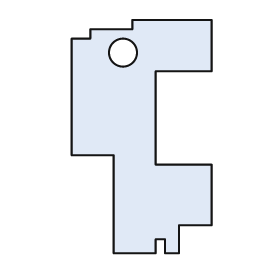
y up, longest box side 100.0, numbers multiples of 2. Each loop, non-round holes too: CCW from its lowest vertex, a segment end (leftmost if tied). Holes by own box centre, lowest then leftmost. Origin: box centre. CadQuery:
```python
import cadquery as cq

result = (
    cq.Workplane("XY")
    .moveTo(-12.0, -50.0)
    .lineTo(6.0, -50.0)
    .lineTo(6.0, -44.0)
    .lineTo(10.0, -44.0)
    .lineTo(10.0, -50.0)
    .lineTo(16.0, -50.0)
    .lineTo(16.0, -38.0)
    .lineTo(30.0, -38.0)
    .lineTo(30.0, -12.0)
    .lineTo(6.0, -12.0)
    .lineTo(6.0, 28.0)
    .lineTo(30.0, 28.0)
    .lineTo(30.0, 50.0)
    .lineTo(-4.0, 50.0)
    .lineTo(-4.0, 46.0)
    .lineTo(-22.0, 46.0)
    .lineTo(-22.0, 42.0)
    .lineTo(-30.0, 42.0)
    .lineTo(-30.0, -8.0)
    .lineTo(-12.0, -8.0)
    .close()
    .moveTo(-8.0, 36.0)
    .circle(6.0)
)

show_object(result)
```